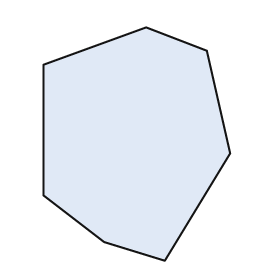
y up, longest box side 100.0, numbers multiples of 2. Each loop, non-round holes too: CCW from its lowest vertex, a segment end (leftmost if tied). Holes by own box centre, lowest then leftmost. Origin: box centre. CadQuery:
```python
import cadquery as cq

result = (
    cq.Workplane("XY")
    .moveTo(12.0, -50.0)
    .lineTo(40.0, -4.0)
    .lineTo(30.0, 40.0)
    .lineTo(4.0, 50.0)
    .lineTo(-40.0, 34.0)
    .lineTo(-40.0, -22.0)
    .lineTo(-14.0, -42.0)
    .close()
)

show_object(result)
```